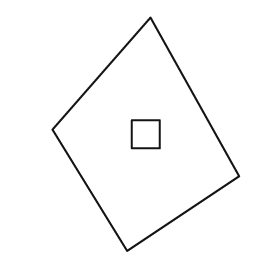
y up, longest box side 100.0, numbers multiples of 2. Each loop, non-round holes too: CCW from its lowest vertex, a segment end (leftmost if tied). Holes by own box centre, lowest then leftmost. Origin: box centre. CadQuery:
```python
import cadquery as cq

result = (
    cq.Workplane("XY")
    .moveTo(-8.0, -50.0)
    .lineTo(40.0, -18.0)
    .lineTo(2.0, 50.0)
    .lineTo(-40.0, 2.0)
    .close()
    .moveTo(-6.0, -6.0)
    .lineTo(6.0, -6.0)
    .lineTo(6.0, 6.0)
    .lineTo(-6.0, 6.0)
    .close()
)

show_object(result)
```